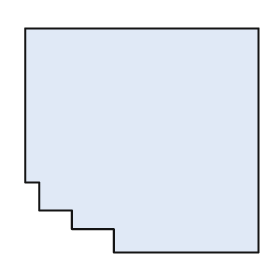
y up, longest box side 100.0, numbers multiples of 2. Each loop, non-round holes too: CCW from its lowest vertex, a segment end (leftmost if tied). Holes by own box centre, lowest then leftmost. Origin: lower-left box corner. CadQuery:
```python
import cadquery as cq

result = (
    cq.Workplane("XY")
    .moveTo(38.0, 0.0)
    .lineTo(100.0, 0.0)
    .lineTo(100.0, 96.0)
    .lineTo(0.0, 96.0)
    .lineTo(0.0, 30.0)
    .lineTo(6.0, 30.0)
    .lineTo(6.0, 18.0)
    .lineTo(20.0, 18.0)
    .lineTo(20.0, 10.0)
    .lineTo(38.0, 10.0)
    .close()
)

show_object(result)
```